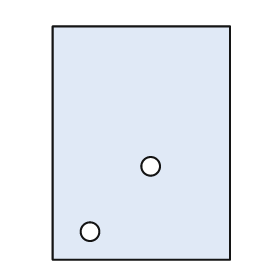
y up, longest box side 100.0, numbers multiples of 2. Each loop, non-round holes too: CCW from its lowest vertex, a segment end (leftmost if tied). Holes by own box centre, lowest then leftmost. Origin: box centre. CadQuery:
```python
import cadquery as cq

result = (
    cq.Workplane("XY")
    .moveTo(-38.0, -50.0)
    .lineTo(38.0, -50.0)
    .lineTo(38.0, 50.0)
    .lineTo(-38.0, 50.0)
    .close()
    .moveTo(-22.0, -38.0)
    .circle(4.0)
    .moveTo(4.0, -10.0)
    .circle(4.0)
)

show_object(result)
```